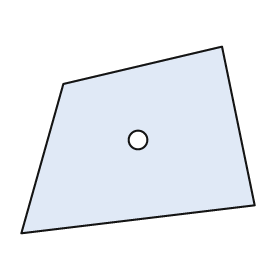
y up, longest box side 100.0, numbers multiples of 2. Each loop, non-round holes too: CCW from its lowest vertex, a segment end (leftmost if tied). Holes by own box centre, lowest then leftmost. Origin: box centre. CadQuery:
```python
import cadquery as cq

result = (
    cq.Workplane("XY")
    .moveTo(-50.0, -40.0)
    .lineTo(50.0, -28.0)
    .lineTo(36.0, 40.0)
    .lineTo(-32.0, 24.0)
    .close()
    .moveTo(0.0, 0.0)
    .circle(4.0)
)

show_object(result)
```